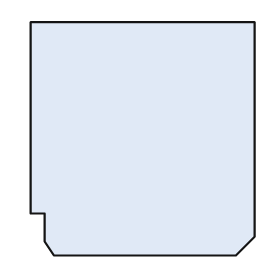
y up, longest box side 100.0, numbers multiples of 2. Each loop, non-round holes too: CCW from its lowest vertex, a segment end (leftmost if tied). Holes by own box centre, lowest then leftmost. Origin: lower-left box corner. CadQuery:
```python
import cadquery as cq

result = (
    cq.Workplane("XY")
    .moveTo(10.0, 0.0)
    .lineTo(88.0, 0.0)
    .lineTo(96.0, 8.0)
    .lineTo(96.0, 100.0)
    .lineTo(0.0, 100.0)
    .lineTo(0.0, 18.0)
    .lineTo(6.0, 18.0)
    .lineTo(6.0, 6.0)
    .close()
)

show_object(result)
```